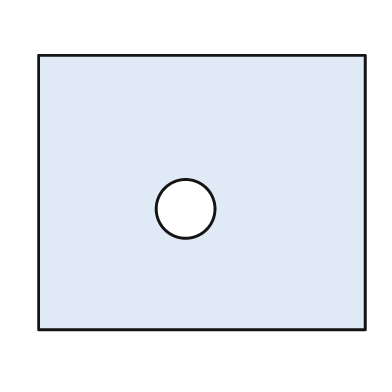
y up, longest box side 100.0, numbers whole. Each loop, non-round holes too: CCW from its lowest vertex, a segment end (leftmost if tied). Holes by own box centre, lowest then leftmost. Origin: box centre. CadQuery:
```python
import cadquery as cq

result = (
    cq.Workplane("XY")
    .moveTo(-50.0, -42.0)
    .lineTo(50.0, -42.0)
    .lineTo(50.0, 42.0)
    .lineTo(-50.0, 42.0)
    .close()
    .moveTo(-5.0, -5.0)
    .circle(9.0)
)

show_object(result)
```